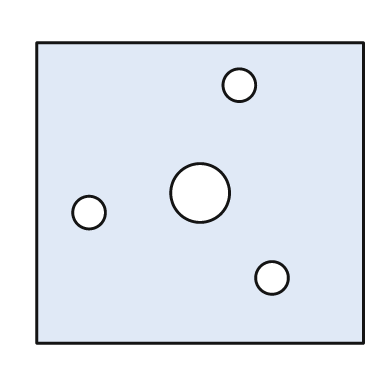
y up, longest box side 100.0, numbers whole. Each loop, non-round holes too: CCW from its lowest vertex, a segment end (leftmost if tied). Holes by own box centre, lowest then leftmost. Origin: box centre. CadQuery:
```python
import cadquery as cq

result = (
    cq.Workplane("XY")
    .moveTo(-50.0, -46.0)
    .lineTo(50.0, -46.0)
    .lineTo(50.0, 46.0)
    .lineTo(-50.0, 46.0)
    .close()
    .moveTo(22.0, -26.0)
    .circle(5.0)
    .moveTo(-34.0, -6.0)
    .circle(5.0)
    .moveTo(0.0, 0.0)
    .circle(9.0)
    .moveTo(12.0, 33.0)
    .circle(5.0)
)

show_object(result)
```